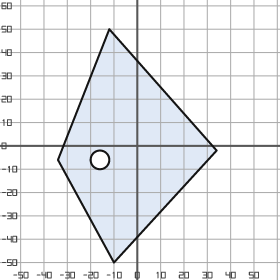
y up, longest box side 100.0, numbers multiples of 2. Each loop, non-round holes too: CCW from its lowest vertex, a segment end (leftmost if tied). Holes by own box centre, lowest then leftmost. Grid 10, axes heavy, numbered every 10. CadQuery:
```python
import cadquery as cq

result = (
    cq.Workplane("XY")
    .moveTo(-10.0, -50.0)
    .lineTo(34.0, -2.0)
    .lineTo(-12.0, 50.0)
    .lineTo(-34.0, -6.0)
    .close()
    .moveTo(-16.0, -6.0)
    .circle(4.0)
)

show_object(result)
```